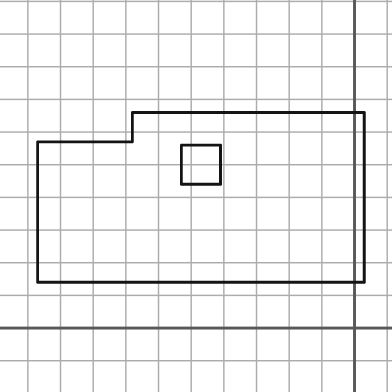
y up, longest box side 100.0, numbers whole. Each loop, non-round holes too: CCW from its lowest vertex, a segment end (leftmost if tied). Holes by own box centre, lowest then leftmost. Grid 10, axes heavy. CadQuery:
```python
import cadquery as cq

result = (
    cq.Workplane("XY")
    .moveTo(-97.0, 14.0)
    .lineTo(3.0, 14.0)
    .lineTo(3.0, 66.0)
    .lineTo(-68.0, 66.0)
    .lineTo(-68.0, 57.0)
    .lineTo(-97.0, 57.0)
    .close()
    .moveTo(-53.0, 44.0)
    .lineTo(-41.0, 44.0)
    .lineTo(-41.0, 56.0)
    .lineTo(-53.0, 56.0)
    .close()
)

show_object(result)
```